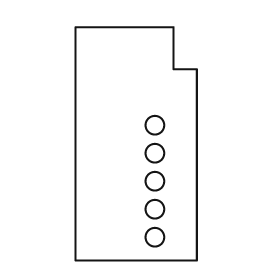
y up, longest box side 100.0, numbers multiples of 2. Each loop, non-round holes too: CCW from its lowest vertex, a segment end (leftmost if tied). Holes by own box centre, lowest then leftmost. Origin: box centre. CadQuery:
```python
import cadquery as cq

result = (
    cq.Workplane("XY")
    .moveTo(-26.0, -50.0)
    .lineTo(26.0, -50.0)
    .lineTo(26.0, 32.0)
    .lineTo(16.0, 32.0)
    .lineTo(16.0, 50.0)
    .lineTo(-26.0, 50.0)
    .close()
    .moveTo(8.0, -40.0)
    .circle(4.0)
    .moveTo(8.0, -28.0)
    .circle(4.0)
    .moveTo(8.0, -16.0)
    .circle(4.0)
    .moveTo(8.0, -4.0)
    .circle(4.0)
    .moveTo(8.0, 8.0)
    .circle(4.0)
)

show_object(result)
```